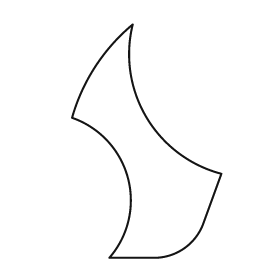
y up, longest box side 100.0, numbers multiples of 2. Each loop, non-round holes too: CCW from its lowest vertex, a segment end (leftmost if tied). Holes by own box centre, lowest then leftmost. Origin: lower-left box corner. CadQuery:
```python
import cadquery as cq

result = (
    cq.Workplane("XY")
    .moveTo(16.0, 0.0)
    .lineTo(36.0, 0.0)
    .threePointArc((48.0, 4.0), (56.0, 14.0))
    .lineTo(64.0, 36.0)
    .threePointArc((32.0, 60.0), (26.0, 100.0))
    .threePointArc((10.0, 82.0), (0.0, 60.0))
    .threePointArc((24.0, 34.0), (16.0, 0.0))
    .close()
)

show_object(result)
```